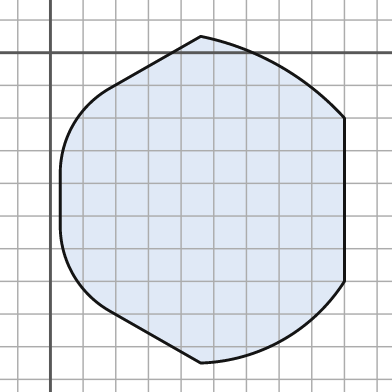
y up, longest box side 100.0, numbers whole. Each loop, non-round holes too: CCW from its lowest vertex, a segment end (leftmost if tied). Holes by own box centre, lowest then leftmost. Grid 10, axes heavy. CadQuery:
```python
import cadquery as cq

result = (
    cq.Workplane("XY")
    .moveTo(46.0, -95.0)
    .threePointArc((71.0, -88.0), (90.0, -70.0))
    .lineTo(90.0, -20.0)
    .threePointArc((70.0, -4.0), (46.0, 5.0))
    .lineTo(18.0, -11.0)
    .threePointArc((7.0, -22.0), (3.0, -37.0))
    .lineTo(3.0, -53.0)
    .threePointArc((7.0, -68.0), (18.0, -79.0))
    .close()
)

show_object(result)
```